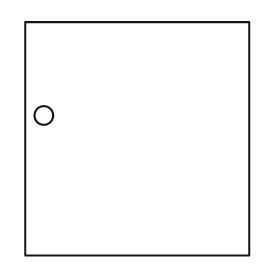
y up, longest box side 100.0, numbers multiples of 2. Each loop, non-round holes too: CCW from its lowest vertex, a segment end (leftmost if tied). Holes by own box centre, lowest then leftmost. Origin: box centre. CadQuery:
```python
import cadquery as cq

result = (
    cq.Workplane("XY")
    .moveTo(-48.0, -50.0)
    .lineTo(48.0, -50.0)
    .lineTo(48.0, 50.0)
    .lineTo(-48.0, 50.0)
    .close()
    .moveTo(-40.0, 10.0)
    .circle(4.0)
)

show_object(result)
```